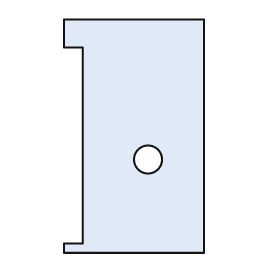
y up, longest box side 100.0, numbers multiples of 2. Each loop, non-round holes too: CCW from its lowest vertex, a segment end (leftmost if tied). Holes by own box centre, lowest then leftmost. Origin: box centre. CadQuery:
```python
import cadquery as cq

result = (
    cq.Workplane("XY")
    .moveTo(-30.0, -50.0)
    .lineTo(30.0, -50.0)
    .lineTo(30.0, 50.0)
    .lineTo(-30.0, 50.0)
    .lineTo(-30.0, 38.0)
    .lineTo(-22.0, 38.0)
    .lineTo(-22.0, -46.0)
    .lineTo(-30.0, -46.0)
    .close()
    .moveTo(6.0, -10.0)
    .circle(6.0)
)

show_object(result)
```